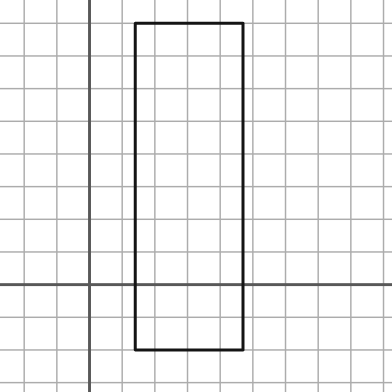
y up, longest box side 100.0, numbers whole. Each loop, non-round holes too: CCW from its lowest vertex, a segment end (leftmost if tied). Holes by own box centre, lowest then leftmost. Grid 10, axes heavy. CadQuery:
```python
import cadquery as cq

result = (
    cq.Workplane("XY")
    .moveTo(14.0, -20.0)
    .lineTo(47.0, -20.0)
    .lineTo(47.0, 80.0)
    .lineTo(14.0, 80.0)
    .close()
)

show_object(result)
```